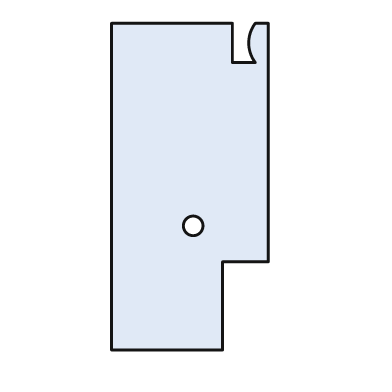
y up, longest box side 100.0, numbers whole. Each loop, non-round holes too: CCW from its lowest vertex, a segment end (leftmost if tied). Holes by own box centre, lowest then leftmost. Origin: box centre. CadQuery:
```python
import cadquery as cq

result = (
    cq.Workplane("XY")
    .moveTo(-24.0, -50.0)
    .lineTo(10.0, -50.0)
    .lineTo(10.0, -23.0)
    .lineTo(24.0, -23.0)
    .lineTo(24.0, 50.0)
    .lineTo(20.0, 50.0)
    .threePointArc((18.0, 44.0), (20.0, 38.0))
    .lineTo(13.0, 38.0)
    .lineTo(13.0, 50.0)
    .lineTo(-24.0, 50.0)
    .close()
    .moveTo(1.0, -12.0)
    .circle(3.0)
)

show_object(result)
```